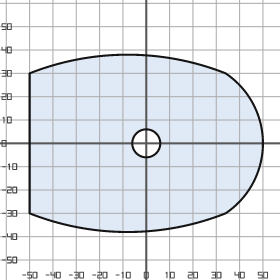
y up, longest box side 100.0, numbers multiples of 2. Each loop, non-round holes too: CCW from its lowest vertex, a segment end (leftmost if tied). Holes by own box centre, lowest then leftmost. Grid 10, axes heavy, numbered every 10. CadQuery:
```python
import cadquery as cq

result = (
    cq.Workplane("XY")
    .moveTo(-50.0, -30.0)
    .threePointArc((-8.0, -38.0), (34.0, -30.0))
    .threePointArc((50.0, 0.0), (34.0, 30.0))
    .threePointArc((-8.0, 38.0), (-50.0, 30.0))
    .close()
    .moveTo(0.0, 0.0)
    .circle(6.0)
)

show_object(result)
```